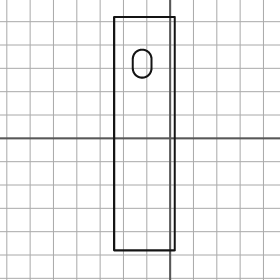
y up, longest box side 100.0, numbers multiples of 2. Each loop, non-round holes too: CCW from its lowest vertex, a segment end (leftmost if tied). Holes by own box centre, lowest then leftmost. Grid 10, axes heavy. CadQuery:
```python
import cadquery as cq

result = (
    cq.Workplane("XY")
    .moveTo(-24.0, -48.0)
    .lineTo(2.0, -48.0)
    .lineTo(2.0, 52.0)
    .lineTo(-24.0, 52.0)
    .close()
    .moveTo(-16.0, 30.0)
    .threePointArc((-12.0, 26.0), (-8.0, 30.0))
    .lineTo(-8.0, 34.0)
    .threePointArc((-12.0, 38.0), (-16.0, 34.0))
    .close()
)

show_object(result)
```